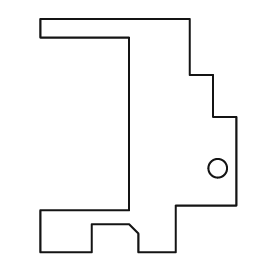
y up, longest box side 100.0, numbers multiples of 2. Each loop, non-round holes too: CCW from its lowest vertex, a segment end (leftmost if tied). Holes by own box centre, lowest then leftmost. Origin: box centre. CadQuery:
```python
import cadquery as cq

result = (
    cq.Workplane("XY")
    .moveTo(-42.0, -50.0)
    .lineTo(-20.0, -50.0)
    .lineTo(-20.0, -38.0)
    .lineTo(-4.0, -38.0)
    .lineTo(0.0, -42.0)
    .lineTo(0.0, -50.0)
    .lineTo(16.0, -50.0)
    .lineTo(16.0, -30.0)
    .lineTo(42.0, -30.0)
    .lineTo(42.0, 8.0)
    .lineTo(32.0, 8.0)
    .lineTo(32.0, 26.0)
    .lineTo(22.0, 26.0)
    .lineTo(22.0, 50.0)
    .lineTo(-42.0, 50.0)
    .lineTo(-42.0, 42.0)
    .lineTo(-4.0, 42.0)
    .lineTo(-4.0, -32.0)
    .lineTo(-42.0, -32.0)
    .close()
    .moveTo(34.0, -14.0)
    .circle(4.0)
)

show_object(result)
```